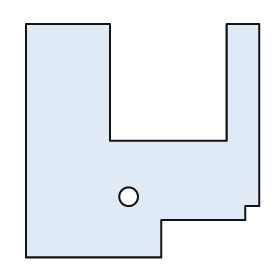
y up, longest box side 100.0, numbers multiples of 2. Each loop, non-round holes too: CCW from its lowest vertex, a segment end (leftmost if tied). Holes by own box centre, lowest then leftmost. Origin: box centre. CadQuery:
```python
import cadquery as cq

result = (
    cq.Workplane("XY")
    .moveTo(-50.0, -50.0)
    .lineTo(8.0, -50.0)
    .lineTo(8.0, -34.0)
    .lineTo(44.0, -34.0)
    .lineTo(44.0, -28.0)
    .lineTo(50.0, -28.0)
    .lineTo(50.0, 50.0)
    .lineTo(36.0, 50.0)
    .lineTo(36.0, 0.0)
    .lineTo(-14.0, 0.0)
    .lineTo(-14.0, 50.0)
    .lineTo(-50.0, 50.0)
    .close()
    .moveTo(-6.0, -24.0)
    .circle(4.0)
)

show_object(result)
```